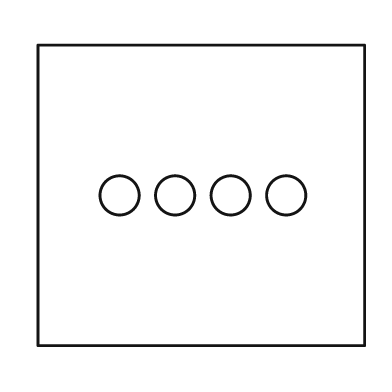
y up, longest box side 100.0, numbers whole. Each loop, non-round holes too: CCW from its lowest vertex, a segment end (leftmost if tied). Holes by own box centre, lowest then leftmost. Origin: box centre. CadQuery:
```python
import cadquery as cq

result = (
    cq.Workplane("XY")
    .moveTo(-50.0, -46.0)
    .lineTo(50.0, -46.0)
    .lineTo(50.0, 46.0)
    .lineTo(-50.0, 46.0)
    .close()
    .moveTo(-25.0, 0.0)
    .circle(6.0)
    .moveTo(-8.0, 0.0)
    .circle(6.0)
    .moveTo(9.0, 0.0)
    .circle(6.0)
    .moveTo(26.0, 0.0)
    .circle(6.0)
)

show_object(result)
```